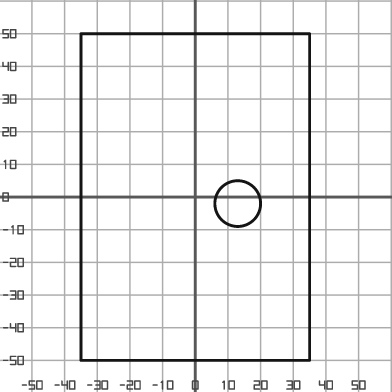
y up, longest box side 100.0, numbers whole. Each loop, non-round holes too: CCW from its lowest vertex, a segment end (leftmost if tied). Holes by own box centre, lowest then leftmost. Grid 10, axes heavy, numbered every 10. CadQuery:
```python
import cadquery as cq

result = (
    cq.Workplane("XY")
    .moveTo(-35.0, -50.0)
    .lineTo(35.0, -50.0)
    .lineTo(35.0, 50.0)
    .lineTo(-35.0, 50.0)
    .close()
    .moveTo(13.0, -2.0)
    .circle(7.0)
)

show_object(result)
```